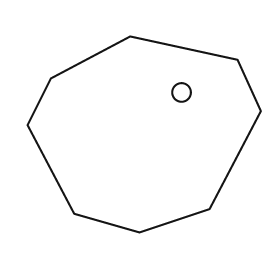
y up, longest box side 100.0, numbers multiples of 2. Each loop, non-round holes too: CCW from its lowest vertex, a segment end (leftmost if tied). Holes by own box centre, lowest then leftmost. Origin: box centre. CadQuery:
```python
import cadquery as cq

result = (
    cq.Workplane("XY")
    .moveTo(-2.0, -42.0)
    .lineTo(28.0, -32.0)
    .lineTo(50.0, 10.0)
    .lineTo(40.0, 32.0)
    .lineTo(-6.0, 42.0)
    .lineTo(-40.0, 24.0)
    .lineTo(-50.0, 4.0)
    .lineTo(-30.0, -34.0)
    .close()
    .moveTo(16.0, 18.0)
    .circle(4.0)
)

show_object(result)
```